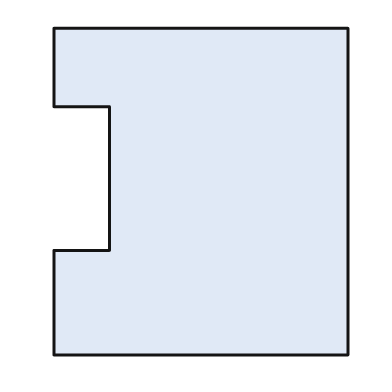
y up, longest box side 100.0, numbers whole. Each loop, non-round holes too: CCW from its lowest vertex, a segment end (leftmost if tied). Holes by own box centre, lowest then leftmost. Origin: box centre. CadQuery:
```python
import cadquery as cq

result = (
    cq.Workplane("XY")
    .moveTo(-45.0, -50.0)
    .lineTo(45.0, -50.0)
    .lineTo(45.0, 50.0)
    .lineTo(-45.0, 50.0)
    .lineTo(-45.0, 26.0)
    .lineTo(-28.0, 26.0)
    .lineTo(-28.0, -18.0)
    .lineTo(-45.0, -18.0)
    .close()
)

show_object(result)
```